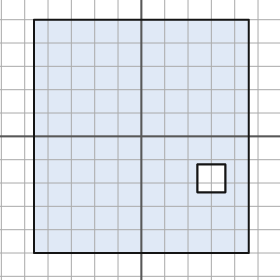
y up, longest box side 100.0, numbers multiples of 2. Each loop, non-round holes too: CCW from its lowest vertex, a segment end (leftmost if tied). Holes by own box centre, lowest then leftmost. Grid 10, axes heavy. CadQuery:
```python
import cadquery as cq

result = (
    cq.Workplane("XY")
    .moveTo(-46.0, -50.0)
    .lineTo(46.0, -50.0)
    .lineTo(46.0, 50.0)
    .lineTo(-46.0, 50.0)
    .close()
    .moveTo(24.0, -24.0)
    .lineTo(36.0, -24.0)
    .lineTo(36.0, -12.0)
    .lineTo(24.0, -12.0)
    .close()
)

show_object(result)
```